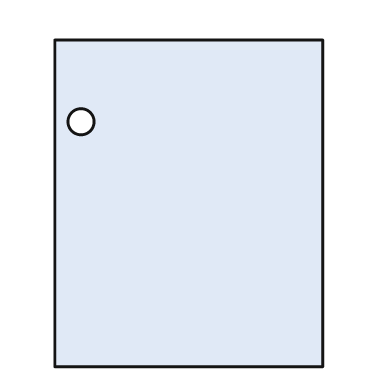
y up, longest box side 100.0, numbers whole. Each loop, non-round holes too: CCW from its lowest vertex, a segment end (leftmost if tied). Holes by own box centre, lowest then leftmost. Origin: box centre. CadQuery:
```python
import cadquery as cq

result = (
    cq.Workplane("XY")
    .moveTo(-41.0, -50.0)
    .lineTo(41.0, -50.0)
    .lineTo(41.0, 50.0)
    .lineTo(-41.0, 50.0)
    .close()
    .moveTo(-33.0, 25.0)
    .circle(4.0)
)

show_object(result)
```